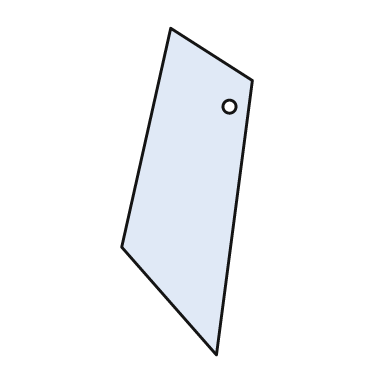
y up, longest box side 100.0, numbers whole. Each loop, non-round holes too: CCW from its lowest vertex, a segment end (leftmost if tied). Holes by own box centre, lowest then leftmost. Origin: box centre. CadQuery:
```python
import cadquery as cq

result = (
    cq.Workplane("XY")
    .moveTo(9.0, -50.0)
    .lineTo(20.0, 34.0)
    .lineTo(-5.0, 50.0)
    .lineTo(-20.0, -17.0)
    .close()
    .moveTo(13.0, 26.0)
    .circle(2.0)
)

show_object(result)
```